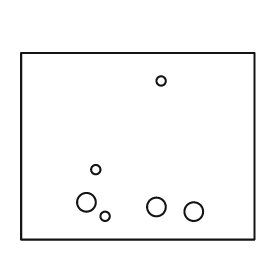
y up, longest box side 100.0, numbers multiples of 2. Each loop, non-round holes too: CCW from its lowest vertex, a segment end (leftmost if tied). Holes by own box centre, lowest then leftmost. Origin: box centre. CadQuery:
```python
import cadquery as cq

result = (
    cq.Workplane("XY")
    .moveTo(-50.0, -40.0)
    .lineTo(50.0, -40.0)
    .lineTo(50.0, 40.0)
    .lineTo(-50.0, 40.0)
    .close()
    .moveTo(-14.0, -30.0)
    .circle(2.0)
    .moveTo(24.0, -28.0)
    .circle(4.0)
    .moveTo(8.0, -26.0)
    .circle(4.0)
    .moveTo(-22.0, -24.0)
    .circle(4.0)
    .moveTo(-18.0, -10.0)
    .circle(2.0)
    .moveTo(10.0, 28.0)
    .circle(2.0)
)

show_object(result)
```